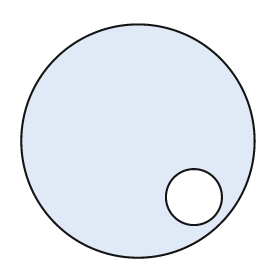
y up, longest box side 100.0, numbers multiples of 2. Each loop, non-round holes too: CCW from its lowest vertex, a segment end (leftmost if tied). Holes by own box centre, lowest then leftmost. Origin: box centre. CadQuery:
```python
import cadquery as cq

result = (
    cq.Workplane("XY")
    .moveTo(0.0, 0.0)
    .circle(50.0)
    .moveTo(24.0, -24.0)
    .circle(12.0)
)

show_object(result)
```